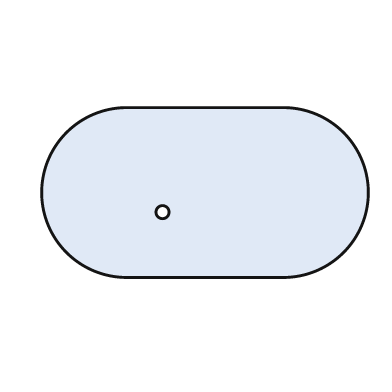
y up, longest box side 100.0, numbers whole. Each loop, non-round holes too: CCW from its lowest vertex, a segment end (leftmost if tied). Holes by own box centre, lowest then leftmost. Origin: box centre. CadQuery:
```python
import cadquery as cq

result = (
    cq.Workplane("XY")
    .moveTo(-24.0, -26.0)
    .lineTo(24.0, -26.0)
    .threePointArc((50.0, 0.0), (24.0, 26.0))
    .lineTo(-24.0, 26.0)
    .threePointArc((-50.0, 0.0), (-24.0, -26.0))
    .close()
    .moveTo(-13.0, -6.0)
    .circle(2.0)
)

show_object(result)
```